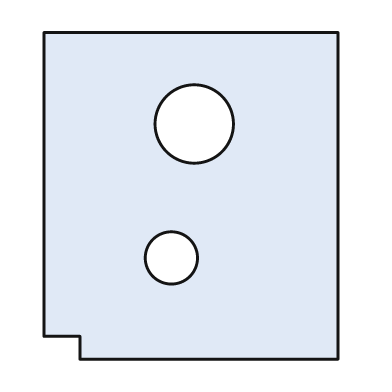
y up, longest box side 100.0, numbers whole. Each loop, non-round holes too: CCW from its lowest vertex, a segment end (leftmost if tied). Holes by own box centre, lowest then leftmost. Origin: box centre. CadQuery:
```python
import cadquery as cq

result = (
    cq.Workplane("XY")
    .moveTo(-34.0, -50.0)
    .lineTo(45.0, -50.0)
    .lineTo(45.0, 50.0)
    .lineTo(-45.0, 50.0)
    .lineTo(-45.0, -43.0)
    .lineTo(-34.0, -43.0)
    .close()
    .moveTo(-6.0, -19.0)
    .circle(8.0)
    .moveTo(1.0, 22.0)
    .circle(12.0)
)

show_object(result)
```